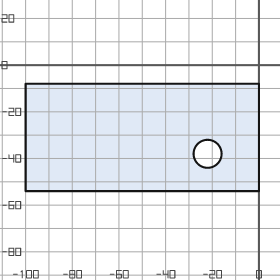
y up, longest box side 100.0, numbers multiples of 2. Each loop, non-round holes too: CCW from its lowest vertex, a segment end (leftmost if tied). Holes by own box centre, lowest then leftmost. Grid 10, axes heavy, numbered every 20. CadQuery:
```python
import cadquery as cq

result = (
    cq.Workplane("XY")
    .moveTo(-100.0, -54.0)
    .lineTo(0.0, -54.0)
    .lineTo(0.0, -8.0)
    .lineTo(-100.0, -8.0)
    .close()
    .moveTo(-22.0, -38.0)
    .circle(6.0)
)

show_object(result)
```